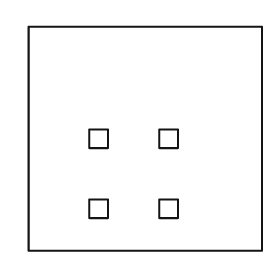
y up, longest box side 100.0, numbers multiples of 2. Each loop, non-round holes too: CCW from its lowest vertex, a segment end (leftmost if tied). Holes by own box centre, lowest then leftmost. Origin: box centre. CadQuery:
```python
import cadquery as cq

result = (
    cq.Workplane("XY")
    .moveTo(-50.0, -48.0)
    .lineTo(50.0, -48.0)
    .lineTo(50.0, 48.0)
    .lineTo(-50.0, 48.0)
    .close()
    .moveTo(-24.0, -34.0)
    .lineTo(-16.0, -34.0)
    .lineTo(-16.0, -26.0)
    .lineTo(-24.0, -26.0)
    .close()
    .moveTo(6.0, -34.0)
    .lineTo(14.0, -34.0)
    .lineTo(14.0, -26.0)
    .lineTo(6.0, -26.0)
    .close()
    .moveTo(-24.0, -4.0)
    .lineTo(-16.0, -4.0)
    .lineTo(-16.0, 4.0)
    .lineTo(-24.0, 4.0)
    .close()
    .moveTo(6.0, -4.0)
    .lineTo(14.0, -4.0)
    .lineTo(14.0, 4.0)
    .lineTo(6.0, 4.0)
    .close()
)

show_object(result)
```